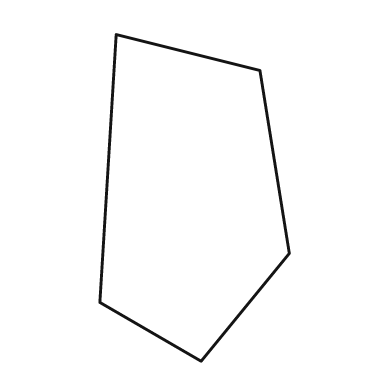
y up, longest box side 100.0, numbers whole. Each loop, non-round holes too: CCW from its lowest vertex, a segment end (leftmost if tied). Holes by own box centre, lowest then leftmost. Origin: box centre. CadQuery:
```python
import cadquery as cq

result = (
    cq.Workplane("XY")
    .moveTo(2.0, -50.0)
    .lineTo(29.0, -17.0)
    .lineTo(20.0, 39.0)
    .lineTo(-24.0, 50.0)
    .lineTo(-29.0, -32.0)
    .close()
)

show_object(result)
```